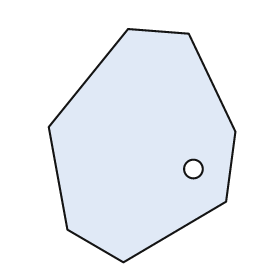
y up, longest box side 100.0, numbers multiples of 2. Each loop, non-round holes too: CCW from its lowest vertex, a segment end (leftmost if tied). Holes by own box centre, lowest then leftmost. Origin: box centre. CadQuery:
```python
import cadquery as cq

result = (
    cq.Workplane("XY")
    .moveTo(-8.0, -50.0)
    .lineTo(36.0, -24.0)
    .lineTo(40.0, 6.0)
    .lineTo(20.0, 48.0)
    .lineTo(-6.0, 50.0)
    .lineTo(-40.0, 8.0)
    .lineTo(-32.0, -36.0)
    .close()
    .moveTo(22.0, -10.0)
    .circle(4.0)
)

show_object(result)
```